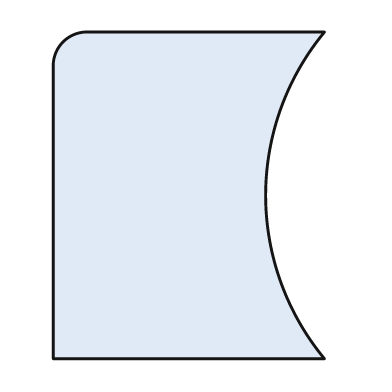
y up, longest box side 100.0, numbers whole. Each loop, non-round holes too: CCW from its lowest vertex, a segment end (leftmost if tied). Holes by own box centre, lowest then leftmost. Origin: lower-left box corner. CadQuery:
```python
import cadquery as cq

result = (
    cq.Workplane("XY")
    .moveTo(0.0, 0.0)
    .lineTo(83.0, 0.0)
    .threePointArc((65.0, 50.0), (83.0, 100.0))
    .lineTo(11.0, 100.0)
    .threePointArc((3.0, 97.0), (0.0, 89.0))
    .close()
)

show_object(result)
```